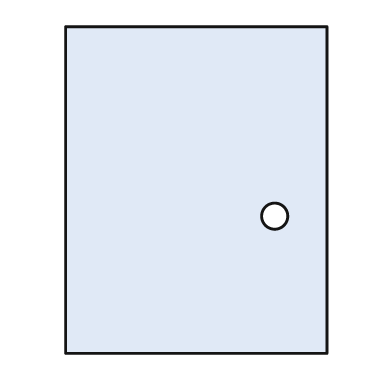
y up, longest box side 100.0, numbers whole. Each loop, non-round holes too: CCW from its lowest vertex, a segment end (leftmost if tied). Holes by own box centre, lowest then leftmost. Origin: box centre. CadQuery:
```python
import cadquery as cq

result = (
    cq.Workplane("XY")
    .moveTo(-40.0, -50.0)
    .lineTo(40.0, -50.0)
    .lineTo(40.0, 50.0)
    .lineTo(-40.0, 50.0)
    .close()
    .moveTo(24.0, -8.0)
    .circle(4.0)
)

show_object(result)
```